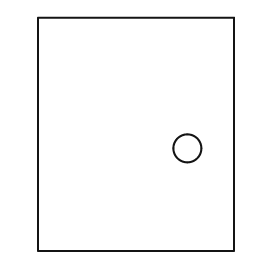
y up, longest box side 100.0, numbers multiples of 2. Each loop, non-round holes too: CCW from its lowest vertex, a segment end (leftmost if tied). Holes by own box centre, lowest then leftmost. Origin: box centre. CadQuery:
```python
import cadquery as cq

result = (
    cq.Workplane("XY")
    .moveTo(-42.0, -50.0)
    .lineTo(42.0, -50.0)
    .lineTo(42.0, 50.0)
    .lineTo(-42.0, 50.0)
    .close()
    .moveTo(22.0, -6.0)
    .circle(6.0)
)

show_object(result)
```